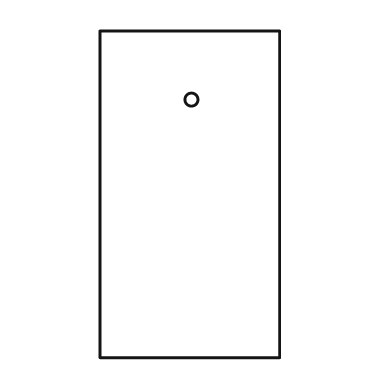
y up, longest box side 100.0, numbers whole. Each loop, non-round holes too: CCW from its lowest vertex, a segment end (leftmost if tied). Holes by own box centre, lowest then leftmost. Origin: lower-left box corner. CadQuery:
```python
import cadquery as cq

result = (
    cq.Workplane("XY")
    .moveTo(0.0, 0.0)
    .lineTo(55.0, 0.0)
    .lineTo(55.0, 100.0)
    .lineTo(0.0, 100.0)
    .close()
    .moveTo(28.0, 79.0)
    .circle(2.0)
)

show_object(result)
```